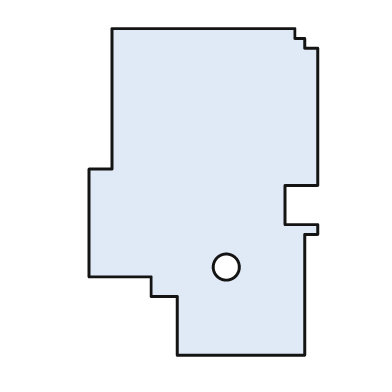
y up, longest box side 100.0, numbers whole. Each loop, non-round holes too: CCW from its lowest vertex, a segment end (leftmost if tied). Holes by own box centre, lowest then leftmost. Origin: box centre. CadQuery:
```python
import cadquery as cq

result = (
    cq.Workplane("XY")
    .moveTo(-8.0, -50.0)
    .lineTo(31.0, -50.0)
    .lineTo(31.0, -13.0)
    .lineTo(35.0, -13.0)
    .lineTo(35.0, -10.0)
    .lineTo(25.0, -10.0)
    .lineTo(25.0, 2.0)
    .lineTo(35.0, 2.0)
    .lineTo(35.0, 44.0)
    .lineTo(31.0, 44.0)
    .lineTo(31.0, 47.0)
    .lineTo(28.0, 47.0)
    .lineTo(28.0, 50.0)
    .lineTo(-28.0, 50.0)
    .lineTo(-28.0, 7.0)
    .lineTo(-35.0, 7.0)
    .lineTo(-35.0, -26.0)
    .lineTo(-16.0, -26.0)
    .lineTo(-16.0, -32.0)
    .lineTo(-8.0, -32.0)
    .close()
    .moveTo(7.0, -23.0)
    .circle(4.0)
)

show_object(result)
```